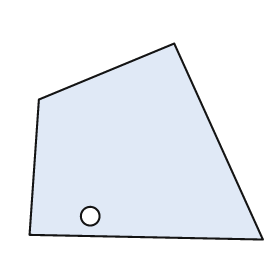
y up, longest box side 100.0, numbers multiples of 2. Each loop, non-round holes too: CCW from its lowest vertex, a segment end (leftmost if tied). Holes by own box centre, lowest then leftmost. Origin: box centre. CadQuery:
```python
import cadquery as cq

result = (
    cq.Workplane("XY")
    .moveTo(50.0, -42.0)
    .lineTo(12.0, 42.0)
    .lineTo(-46.0, 18.0)
    .lineTo(-50.0, -40.0)
    .close()
    .moveTo(-24.0, -32.0)
    .circle(4.0)
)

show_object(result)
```